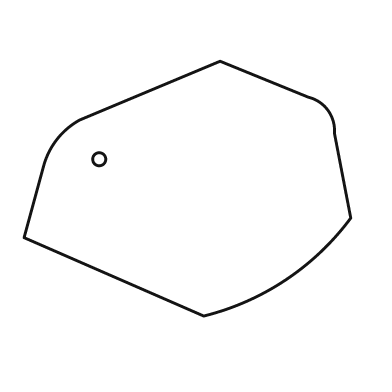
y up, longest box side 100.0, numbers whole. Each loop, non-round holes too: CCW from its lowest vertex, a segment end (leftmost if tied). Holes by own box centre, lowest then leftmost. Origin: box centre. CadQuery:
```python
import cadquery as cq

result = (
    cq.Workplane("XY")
    .moveTo(5.0, -39.0)
    .threePointArc((30.0, -28.0), (50.0, -9.0))
    .lineTo(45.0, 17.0)
    .threePointArc((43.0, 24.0), (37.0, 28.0))
    .lineTo(10.0, 39.0)
    .lineTo(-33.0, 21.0)
    .threePointArc((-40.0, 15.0), (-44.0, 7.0))
    .lineTo(-50.0, -15.0)
    .close()
    .moveTo(-27.0, 9.0)
    .circle(2.0)
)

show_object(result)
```